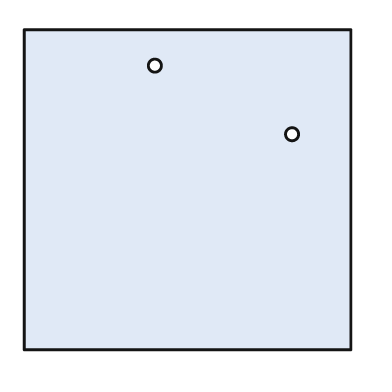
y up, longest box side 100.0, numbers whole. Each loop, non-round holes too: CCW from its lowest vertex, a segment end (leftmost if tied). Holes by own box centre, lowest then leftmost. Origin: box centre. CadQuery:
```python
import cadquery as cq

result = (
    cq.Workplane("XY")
    .moveTo(-50.0, -49.0)
    .lineTo(50.0, -49.0)
    .lineTo(50.0, 49.0)
    .lineTo(-50.0, 49.0)
    .close()
    .moveTo(32.0, 17.0)
    .circle(2.0)
    .moveTo(-10.0, 38.0)
    .circle(2.0)
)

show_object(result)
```